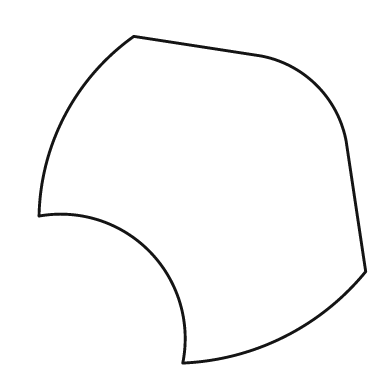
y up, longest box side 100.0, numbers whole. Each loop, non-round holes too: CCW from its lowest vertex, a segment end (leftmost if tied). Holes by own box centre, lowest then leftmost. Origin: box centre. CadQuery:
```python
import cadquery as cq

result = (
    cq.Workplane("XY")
    .moveTo(-6.0, -50.0)
    .threePointArc((25.0, -42.0), (50.0, -22.0))
    .lineTo(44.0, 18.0)
    .threePointArc((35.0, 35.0), (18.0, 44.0))
    .lineTo(-21.0, 50.0)
    .threePointArc((-42.0, 26.0), (-50.0, -5.0))
    .threePointArc((-16.0, -16.0), (-6.0, -50.0))
    .close()
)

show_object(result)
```